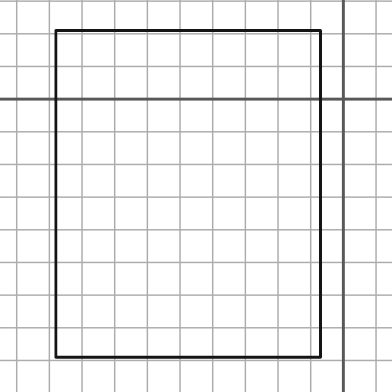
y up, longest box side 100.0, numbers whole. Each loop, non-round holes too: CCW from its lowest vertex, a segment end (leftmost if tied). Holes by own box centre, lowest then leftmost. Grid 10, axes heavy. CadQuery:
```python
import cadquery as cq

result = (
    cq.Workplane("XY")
    .moveTo(-88.0, -79.0)
    .lineTo(-7.0, -79.0)
    .lineTo(-7.0, 21.0)
    .lineTo(-88.0, 21.0)
    .close()
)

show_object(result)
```